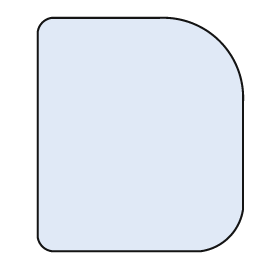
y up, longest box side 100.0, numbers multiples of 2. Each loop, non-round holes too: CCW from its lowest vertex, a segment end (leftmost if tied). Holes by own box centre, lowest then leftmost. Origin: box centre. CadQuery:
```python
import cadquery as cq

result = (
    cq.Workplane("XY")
    .moveTo(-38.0, -50.0)
    .lineTo(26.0, -50.0)
    .threePointArc((38.0, -44.0), (44.0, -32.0))
    .lineTo(44.0, 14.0)
    .threePointArc((34.0, 40.0), (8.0, 50.0))
    .lineTo(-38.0, 50.0)
    .threePointArc((-42.0, 48.0), (-44.0, 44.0))
    .lineTo(-44.0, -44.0)
    .threePointArc((-42.0, -48.0), (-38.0, -50.0))
    .close()
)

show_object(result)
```